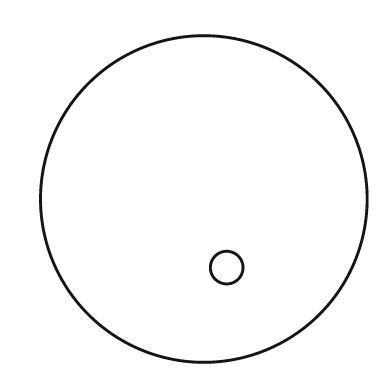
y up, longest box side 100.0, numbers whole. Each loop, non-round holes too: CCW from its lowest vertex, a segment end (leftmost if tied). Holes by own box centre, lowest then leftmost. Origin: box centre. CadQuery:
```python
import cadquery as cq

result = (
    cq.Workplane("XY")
    .moveTo(0.0, 0.0)
    .circle(50.0)
    .moveTo(7.0, -21.0)
    .circle(5.0)
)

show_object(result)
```